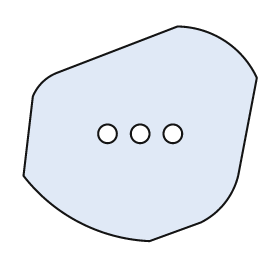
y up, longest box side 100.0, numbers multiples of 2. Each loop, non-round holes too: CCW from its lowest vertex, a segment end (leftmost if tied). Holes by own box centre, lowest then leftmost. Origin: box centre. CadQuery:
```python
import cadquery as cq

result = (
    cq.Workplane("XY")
    .moveTo(4.0, -46.0)
    .lineTo(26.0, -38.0)
    .threePointArc((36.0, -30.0), (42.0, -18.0))
    .lineTo(50.0, 24.0)
    .threePointArc((36.0, 40.0), (16.0, 46.0))
    .lineTo(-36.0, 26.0)
    .threePointArc((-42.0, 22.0), (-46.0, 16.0))
    .lineTo(-50.0, -18.0)
    .threePointArc((-26.0, -38.0), (4.0, -46.0))
    .close()
    .moveTo(-14.0, 0.0)
    .circle(4.0)
    .moveTo(0.0, 0.0)
    .circle(4.0)
    .moveTo(14.0, 0.0)
    .circle(4.0)
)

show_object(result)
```